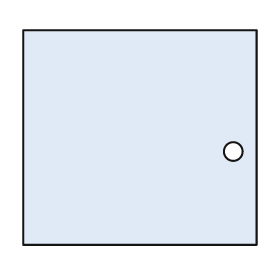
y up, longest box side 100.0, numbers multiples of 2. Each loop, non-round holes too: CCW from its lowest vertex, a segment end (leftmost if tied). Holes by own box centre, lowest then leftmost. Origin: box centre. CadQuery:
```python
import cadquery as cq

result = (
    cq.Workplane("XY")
    .moveTo(-50.0, -46.0)
    .lineTo(50.0, -46.0)
    .lineTo(50.0, 46.0)
    .lineTo(-50.0, 46.0)
    .close()
    .moveTo(40.0, -6.0)
    .circle(4.0)
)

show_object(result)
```